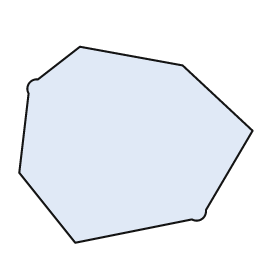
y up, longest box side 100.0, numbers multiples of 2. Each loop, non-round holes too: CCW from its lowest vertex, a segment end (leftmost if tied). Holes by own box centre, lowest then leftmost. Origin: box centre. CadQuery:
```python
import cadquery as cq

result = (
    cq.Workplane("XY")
    .moveTo(-26.0, -42.0)
    .lineTo(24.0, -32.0)
    .threePointArc((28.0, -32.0), (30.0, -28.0))
    .lineTo(50.0, 6.0)
    .lineTo(20.0, 34.0)
    .lineTo(-24.0, 42.0)
    .lineTo(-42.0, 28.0)
    .threePointArc((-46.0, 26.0), (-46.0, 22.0))
    .lineTo(-50.0, -12.0)
    .close()
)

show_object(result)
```